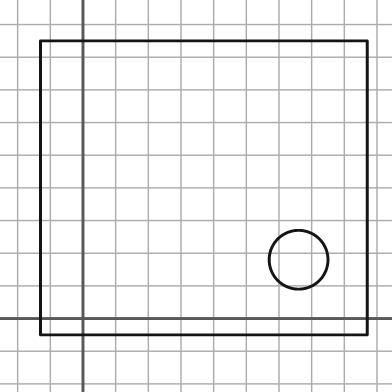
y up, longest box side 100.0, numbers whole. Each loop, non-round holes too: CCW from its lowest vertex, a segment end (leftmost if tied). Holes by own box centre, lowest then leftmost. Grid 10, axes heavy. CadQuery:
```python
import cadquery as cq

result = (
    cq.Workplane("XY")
    .moveTo(-13.0, -5.0)
    .lineTo(87.0, -5.0)
    .lineTo(87.0, 85.0)
    .lineTo(-13.0, 85.0)
    .close()
    .moveTo(66.0, 18.0)
    .circle(9.0)
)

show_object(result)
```